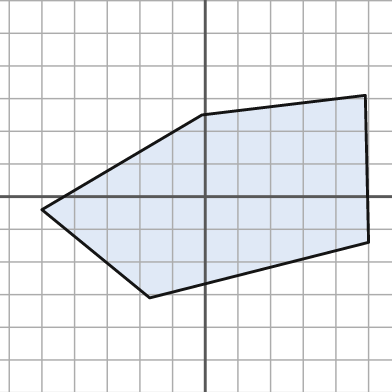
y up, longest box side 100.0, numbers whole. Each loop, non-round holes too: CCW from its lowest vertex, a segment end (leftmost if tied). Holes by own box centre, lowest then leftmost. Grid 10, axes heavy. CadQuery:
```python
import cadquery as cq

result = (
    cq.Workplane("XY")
    .moveTo(-17.0, -31.0)
    .lineTo(50.0, -14.0)
    .lineTo(49.0, 31.0)
    .lineTo(-1.0, 25.0)
    .lineTo(-50.0, -4.0)
    .close()
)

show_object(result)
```